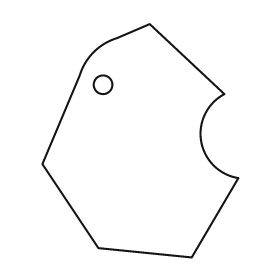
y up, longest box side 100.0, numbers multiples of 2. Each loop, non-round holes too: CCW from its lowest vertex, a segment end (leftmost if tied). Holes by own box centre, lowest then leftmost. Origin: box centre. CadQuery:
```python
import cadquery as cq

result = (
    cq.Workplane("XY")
    .moveTo(22.0, -50.0)
    .lineTo(42.0, -16.0)
    .threePointArc((26.0, 0.0), (36.0, 20.0))
    .lineTo(4.0, 50.0)
    .lineTo(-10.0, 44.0)
    .threePointArc((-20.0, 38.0), (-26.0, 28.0))
    .lineTo(-42.0, -10.0)
    .lineTo(-18.0, -46.0)
    .close()
    .moveTo(-16.0, 24.0)
    .circle(4.0)
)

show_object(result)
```